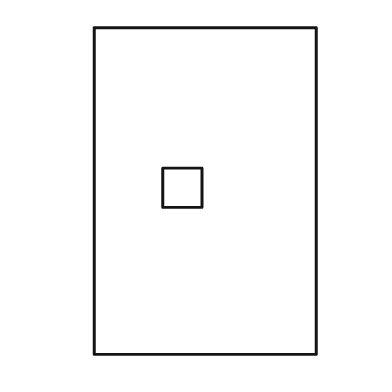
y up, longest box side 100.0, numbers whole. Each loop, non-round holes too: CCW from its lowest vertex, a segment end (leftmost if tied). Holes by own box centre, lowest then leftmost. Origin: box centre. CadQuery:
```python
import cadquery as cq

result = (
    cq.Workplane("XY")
    .moveTo(-34.0, -50.0)
    .lineTo(34.0, -50.0)
    .lineTo(34.0, 50.0)
    .lineTo(-34.0, 50.0)
    .close()
    .moveTo(-13.0, -5.0)
    .lineTo(-1.0, -5.0)
    .lineTo(-1.0, 7.0)
    .lineTo(-13.0, 7.0)
    .close()
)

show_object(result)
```